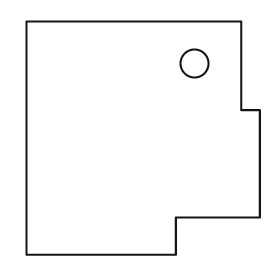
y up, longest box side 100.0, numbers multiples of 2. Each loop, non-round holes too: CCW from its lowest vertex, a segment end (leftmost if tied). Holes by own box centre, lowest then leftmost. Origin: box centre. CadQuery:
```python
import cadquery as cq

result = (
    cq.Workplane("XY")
    .moveTo(-50.0, -50.0)
    .lineTo(14.0, -50.0)
    .lineTo(14.0, -34.0)
    .lineTo(50.0, -34.0)
    .lineTo(50.0, 12.0)
    .lineTo(42.0, 12.0)
    .lineTo(42.0, 50.0)
    .lineTo(-50.0, 50.0)
    .close()
    .moveTo(22.0, 32.0)
    .circle(6.0)
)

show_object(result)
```